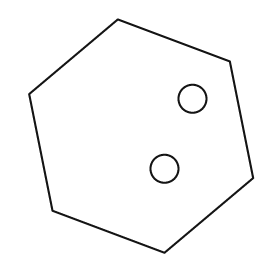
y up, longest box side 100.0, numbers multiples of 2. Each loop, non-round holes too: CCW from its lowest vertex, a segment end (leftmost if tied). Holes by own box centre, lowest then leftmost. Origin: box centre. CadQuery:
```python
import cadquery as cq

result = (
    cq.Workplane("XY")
    .moveTo(10.0, -50.0)
    .lineTo(48.0, -18.0)
    .lineTo(38.0, 32.0)
    .lineTo(-10.0, 50.0)
    .lineTo(-48.0, 18.0)
    .lineTo(-38.0, -32.0)
    .close()
    .moveTo(10.0, -14.0)
    .circle(6.0)
    .moveTo(22.0, 16.0)
    .circle(6.0)
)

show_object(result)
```